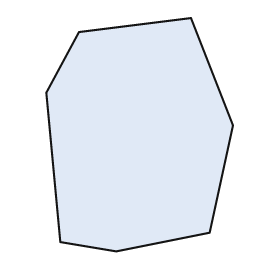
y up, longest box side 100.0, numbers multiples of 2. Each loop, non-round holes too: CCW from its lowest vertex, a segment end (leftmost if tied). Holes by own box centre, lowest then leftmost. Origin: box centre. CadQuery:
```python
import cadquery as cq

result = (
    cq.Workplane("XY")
    .moveTo(-10.0, -50.0)
    .lineTo(30.0, -42.0)
    .lineTo(40.0, 4.0)
    .lineTo(22.0, 50.0)
    .lineTo(-26.0, 44.0)
    .lineTo(-40.0, 18.0)
    .lineTo(-34.0, -46.0)
    .close()
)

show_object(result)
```